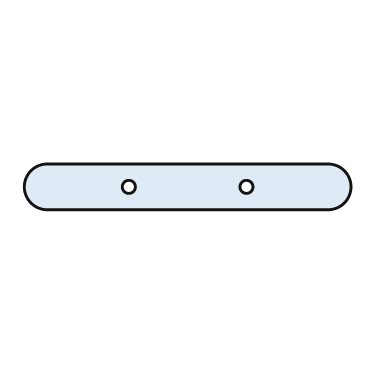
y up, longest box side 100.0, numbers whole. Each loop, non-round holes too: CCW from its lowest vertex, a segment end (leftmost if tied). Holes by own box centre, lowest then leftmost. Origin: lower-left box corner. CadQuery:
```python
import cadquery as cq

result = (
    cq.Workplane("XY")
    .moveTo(7.0, 0.0)
    .lineTo(93.0, 0.0)
    .threePointArc((100.0, 7.0), (93.0, 14.0))
    .lineTo(7.0, 14.0)
    .threePointArc((0.0, 7.0), (7.0, 0.0))
    .close()
    .moveTo(32.0, 7.0)
    .circle(2.0)
    .moveTo(68.0, 7.0)
    .circle(2.0)
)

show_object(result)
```